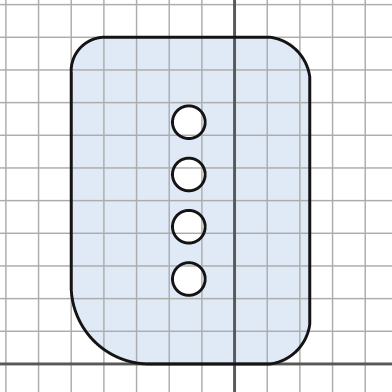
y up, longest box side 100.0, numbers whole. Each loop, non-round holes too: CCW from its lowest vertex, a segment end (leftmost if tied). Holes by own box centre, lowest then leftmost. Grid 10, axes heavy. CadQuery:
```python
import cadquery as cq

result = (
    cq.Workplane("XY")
    .moveTo(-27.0, 0.0)
    .lineTo(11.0, 0.0)
    .threePointArc((19.0, 4.0), (23.0, 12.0))
    .lineTo(23.0, 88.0)
    .threePointArc((19.0, 96.0), (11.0, 100.0))
    .lineTo(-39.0, 100.0)
    .threePointArc((-47.0, 97.0), (-50.0, 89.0))
    .lineTo(-50.0, 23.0)
    .threePointArc((-43.0, 7.0), (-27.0, 0.0))
    .close()
    .moveTo(-14.0, 26.0)
    .circle(5.0)
    .moveTo(-14.0, 42.0)
    .circle(5.0)
    .moveTo(-14.0, 58.0)
    .circle(5.0)
    .moveTo(-14.0, 74.0)
    .circle(5.0)
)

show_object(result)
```